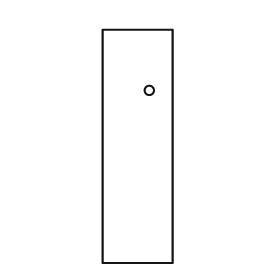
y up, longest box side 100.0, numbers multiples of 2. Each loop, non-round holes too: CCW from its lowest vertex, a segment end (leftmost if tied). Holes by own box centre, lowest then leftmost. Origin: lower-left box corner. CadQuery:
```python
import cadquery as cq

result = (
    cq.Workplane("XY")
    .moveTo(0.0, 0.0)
    .lineTo(30.0, 0.0)
    .lineTo(30.0, 100.0)
    .lineTo(0.0, 100.0)
    .close()
    .moveTo(20.0, 74.0)
    .circle(2.0)
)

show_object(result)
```